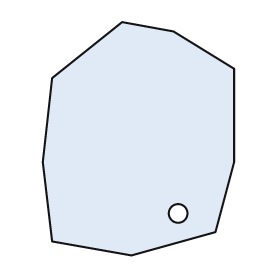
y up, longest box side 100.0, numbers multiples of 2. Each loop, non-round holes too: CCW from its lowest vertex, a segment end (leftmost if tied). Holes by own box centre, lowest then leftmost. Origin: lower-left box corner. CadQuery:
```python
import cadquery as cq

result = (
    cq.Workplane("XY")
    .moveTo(38.0, 0.0)
    .lineTo(74.0, 10.0)
    .lineTo(82.0, 40.0)
    .lineTo(82.0, 80.0)
    .lineTo(56.0, 96.0)
    .lineTo(34.0, 100.0)
    .lineTo(4.0, 76.0)
    .lineTo(0.0, 40.0)
    .lineTo(4.0, 6.0)
    .close()
    .moveTo(58.0, 18.0)
    .circle(4.0)
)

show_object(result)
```